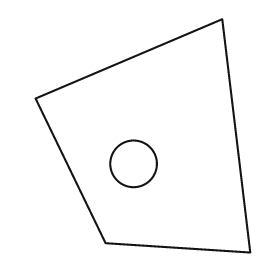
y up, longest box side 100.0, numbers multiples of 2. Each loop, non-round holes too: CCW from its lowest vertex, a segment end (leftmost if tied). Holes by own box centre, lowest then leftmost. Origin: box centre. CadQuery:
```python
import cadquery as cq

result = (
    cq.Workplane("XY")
    .moveTo(46.0, -50.0)
    .lineTo(34.0, 50.0)
    .lineTo(-46.0, 16.0)
    .lineTo(-16.0, -46.0)
    .close()
    .moveTo(-4.0, -12.0)
    .circle(10.0)
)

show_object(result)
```